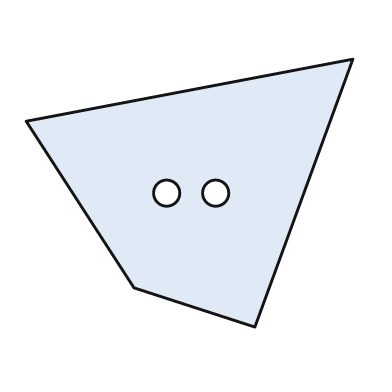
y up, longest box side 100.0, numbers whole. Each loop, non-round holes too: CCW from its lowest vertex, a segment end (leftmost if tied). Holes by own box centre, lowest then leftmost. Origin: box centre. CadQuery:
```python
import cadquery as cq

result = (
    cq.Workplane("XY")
    .moveTo(20.0, -41.0)
    .lineTo(50.0, 41.0)
    .lineTo(-50.0, 22.0)
    .lineTo(-17.0, -29.0)
    .close()
    .moveTo(-7.0, 0.0)
    .circle(4.0)
    .moveTo(8.0, 0.0)
    .circle(4.0)
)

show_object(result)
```